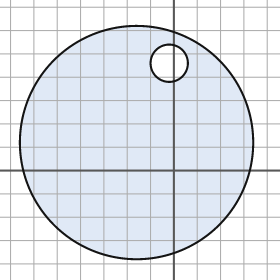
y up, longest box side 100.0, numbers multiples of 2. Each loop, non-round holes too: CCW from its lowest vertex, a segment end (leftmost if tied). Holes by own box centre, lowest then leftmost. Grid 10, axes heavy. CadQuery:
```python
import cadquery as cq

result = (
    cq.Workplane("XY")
    .moveTo(-16.0, 12.0)
    .circle(50.0)
    .moveTo(-2.0, 46.0)
    .circle(8.0)
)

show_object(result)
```